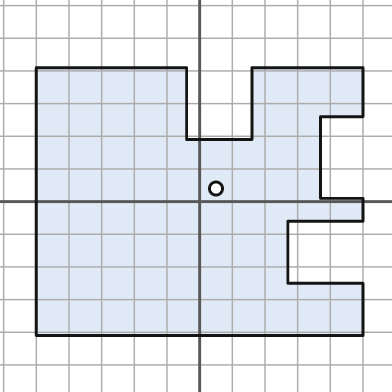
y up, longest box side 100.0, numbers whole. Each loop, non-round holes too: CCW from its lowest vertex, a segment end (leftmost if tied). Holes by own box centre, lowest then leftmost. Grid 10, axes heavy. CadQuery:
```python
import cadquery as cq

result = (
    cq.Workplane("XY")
    .moveTo(-50.0, -41.0)
    .lineTo(50.0, -41.0)
    .lineTo(50.0, -25.0)
    .lineTo(27.0, -25.0)
    .lineTo(27.0, -6.0)
    .lineTo(50.0, -6.0)
    .lineTo(50.0, 1.0)
    .lineTo(37.0, 1.0)
    .lineTo(37.0, 26.0)
    .lineTo(50.0, 26.0)
    .lineTo(50.0, 41.0)
    .lineTo(16.0, 41.0)
    .lineTo(16.0, 19.0)
    .lineTo(-4.0, 19.0)
    .lineTo(-4.0, 41.0)
    .lineTo(-50.0, 41.0)
    .close()
    .moveTo(5.0, 4.0)
    .circle(2.0)
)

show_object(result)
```